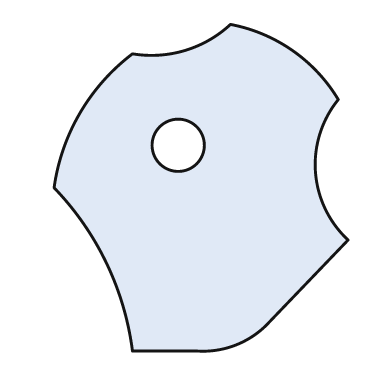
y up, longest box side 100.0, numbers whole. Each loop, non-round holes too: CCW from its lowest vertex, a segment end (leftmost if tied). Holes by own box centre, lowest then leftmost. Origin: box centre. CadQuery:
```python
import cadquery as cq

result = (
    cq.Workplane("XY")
    .moveTo(-21.0, -50.0)
    .lineTo(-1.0, -50.0)
    .threePointArc((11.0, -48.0), (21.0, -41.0))
    .lineTo(45.0, -16.0)
    .threePointArc((35.0, 5.0), (42.0, 27.0))
    .threePointArc((28.0, 42.0), (9.0, 50.0))
    .threePointArc((-5.0, 42.0), (-21.0, 41.0))
    .threePointArc((-37.0, 23.0), (-45.0, 0.0))
    .threePointArc((-29.0, -23.0), (-21.0, -50.0))
    .close()
    .moveTo(-7.0, 13.0)
    .circle(8.0)
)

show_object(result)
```